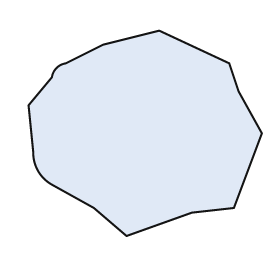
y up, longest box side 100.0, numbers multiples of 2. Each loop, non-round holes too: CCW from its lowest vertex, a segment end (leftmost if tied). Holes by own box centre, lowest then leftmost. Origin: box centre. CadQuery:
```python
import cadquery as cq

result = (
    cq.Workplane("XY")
    .moveTo(-8.0, -44.0)
    .lineTo(20.0, -34.0)
    .lineTo(38.0, -32.0)
    .lineTo(50.0, 0.0)
    .lineTo(40.0, 18.0)
    .lineTo(36.0, 30.0)
    .lineTo(6.0, 44.0)
    .lineTo(-18.0, 38.0)
    .lineTo(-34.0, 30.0)
    .threePointArc((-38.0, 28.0), (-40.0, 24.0))
    .lineTo(-50.0, 12.0)
    .lineTo(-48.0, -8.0)
    .threePointArc((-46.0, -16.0), (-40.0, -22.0))
    .lineTo(-22.0, -32.0)
    .close()
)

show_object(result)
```